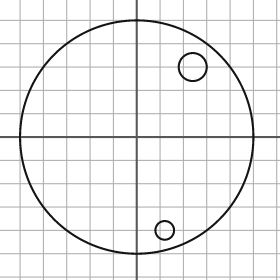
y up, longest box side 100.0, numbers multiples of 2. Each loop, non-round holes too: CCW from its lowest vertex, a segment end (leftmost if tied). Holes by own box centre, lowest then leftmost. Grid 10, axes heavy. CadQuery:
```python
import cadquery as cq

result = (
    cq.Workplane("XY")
    .moveTo(0.0, 0.0)
    .circle(50.0)
    .moveTo(12.0, -40.0)
    .circle(4.0)
    .moveTo(24.0, 30.0)
    .circle(6.0)
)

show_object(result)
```